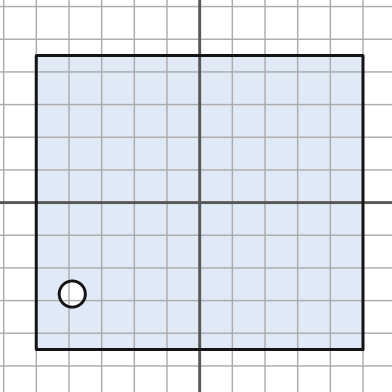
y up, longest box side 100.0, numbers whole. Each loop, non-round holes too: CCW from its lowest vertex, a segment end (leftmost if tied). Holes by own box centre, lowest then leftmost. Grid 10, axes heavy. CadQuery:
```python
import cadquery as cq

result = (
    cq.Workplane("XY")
    .moveTo(-50.0, -45.0)
    .lineTo(50.0, -45.0)
    .lineTo(50.0, 45.0)
    .lineTo(-50.0, 45.0)
    .close()
    .moveTo(-39.0, -28.0)
    .circle(4.0)
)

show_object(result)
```